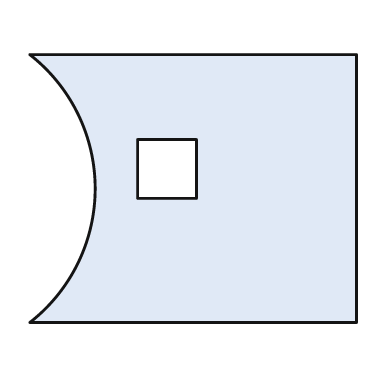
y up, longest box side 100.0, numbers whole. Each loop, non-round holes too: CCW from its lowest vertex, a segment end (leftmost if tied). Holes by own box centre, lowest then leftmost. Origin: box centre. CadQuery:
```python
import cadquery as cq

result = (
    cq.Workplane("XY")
    .moveTo(-50.0, -41.0)
    .lineTo(50.0, -41.0)
    .lineTo(50.0, 41.0)
    .lineTo(-50.0, 41.0)
    .threePointArc((-30.0, 0.0), (-50.0, -41.0))
    .close()
    .moveTo(-17.0, -3.0)
    .lineTo(1.0, -3.0)
    .lineTo(1.0, 15.0)
    .lineTo(-17.0, 15.0)
    .close()
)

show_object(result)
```